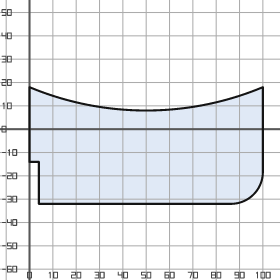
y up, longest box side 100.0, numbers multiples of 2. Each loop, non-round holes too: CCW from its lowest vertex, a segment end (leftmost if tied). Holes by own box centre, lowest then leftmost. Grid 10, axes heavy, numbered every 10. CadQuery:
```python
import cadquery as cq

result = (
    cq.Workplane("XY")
    .moveTo(4.0, -32.0)
    .lineTo(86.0, -32.0)
    .threePointArc((96.0, -28.0), (100.0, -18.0))
    .lineTo(100.0, 18.0)
    .threePointArc((50.0, 8.0), (0.0, 18.0))
    .lineTo(0.0, -14.0)
    .lineTo(4.0, -14.0)
    .close()
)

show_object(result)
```